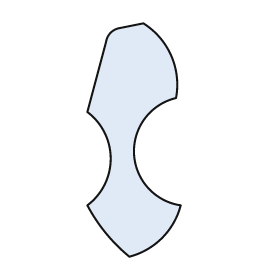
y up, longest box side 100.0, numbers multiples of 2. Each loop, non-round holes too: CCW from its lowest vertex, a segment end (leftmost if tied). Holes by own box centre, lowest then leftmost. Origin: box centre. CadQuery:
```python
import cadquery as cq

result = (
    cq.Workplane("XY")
    .moveTo(-2.0, -50.0)
    .threePointArc((12.0, -42.0), (20.0, -28.0))
    .threePointArc((0.0, -6.0), (18.0, 18.0))
    .threePointArc((16.0, 36.0), (4.0, 50.0))
    .lineTo(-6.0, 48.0)
    .threePointArc((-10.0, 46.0), (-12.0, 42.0))
    .lineTo(-20.0, 12.0)
    .threePointArc((-10.0, -8.0), (-20.0, -28.0))
    .threePointArc((-12.0, -40.0), (-2.0, -50.0))
    .close()
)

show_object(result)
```